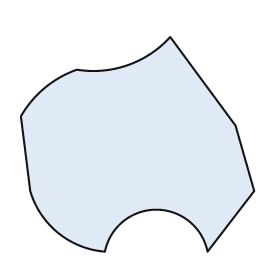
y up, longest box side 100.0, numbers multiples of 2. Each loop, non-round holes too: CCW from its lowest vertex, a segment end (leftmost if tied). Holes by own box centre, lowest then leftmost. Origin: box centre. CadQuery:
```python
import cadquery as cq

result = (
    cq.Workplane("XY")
    .moveTo(-14.0, -46.0)
    .threePointArc((8.0, -28.0), (30.0, -46.0))
    .lineTo(50.0, -20.0)
    .lineTo(42.0, 8.0)
    .lineTo(14.0, 46.0)
    .threePointArc((-4.0, 34.0), (-26.0, 32.0))
    .threePointArc((-40.0, 24.0), (-50.0, 12.0))
    .lineTo(-46.0, -20.0)
    .threePointArc((-34.0, -38.0), (-14.0, -46.0))
    .close()
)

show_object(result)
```